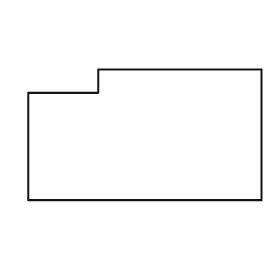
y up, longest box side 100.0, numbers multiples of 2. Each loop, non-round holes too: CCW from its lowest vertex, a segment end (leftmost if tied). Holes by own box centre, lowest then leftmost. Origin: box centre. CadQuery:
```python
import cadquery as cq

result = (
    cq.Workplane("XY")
    .moveTo(-50.0, -28.0)
    .lineTo(50.0, -28.0)
    .lineTo(50.0, 28.0)
    .lineTo(-20.0, 28.0)
    .lineTo(-20.0, 18.0)
    .lineTo(-50.0, 18.0)
    .close()
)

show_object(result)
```